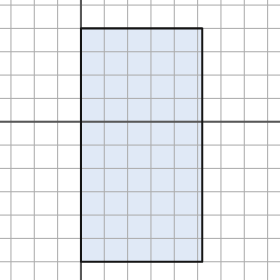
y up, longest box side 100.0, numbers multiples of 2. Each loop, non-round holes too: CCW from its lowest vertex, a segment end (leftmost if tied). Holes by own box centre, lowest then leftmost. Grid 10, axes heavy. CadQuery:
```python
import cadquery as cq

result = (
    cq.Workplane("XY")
    .moveTo(0.0, -60.0)
    .lineTo(52.0, -60.0)
    .lineTo(52.0, 40.0)
    .lineTo(0.0, 40.0)
    .close()
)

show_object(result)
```